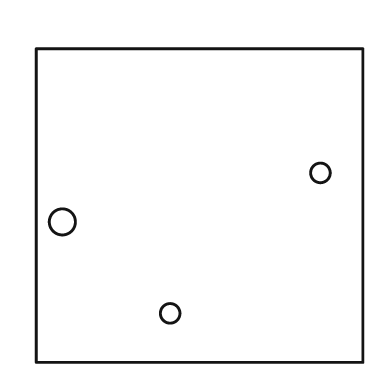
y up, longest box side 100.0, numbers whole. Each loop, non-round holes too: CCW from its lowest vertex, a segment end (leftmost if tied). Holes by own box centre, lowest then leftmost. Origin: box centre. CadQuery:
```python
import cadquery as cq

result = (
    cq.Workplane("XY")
    .moveTo(-50.0, -48.0)
    .lineTo(50.0, -48.0)
    .lineTo(50.0, 48.0)
    .lineTo(-50.0, 48.0)
    .close()
    .moveTo(-9.0, -33.0)
    .circle(3.0)
    .moveTo(-42.0, -5.0)
    .circle(4.0)
    .moveTo(37.0, 10.0)
    .circle(3.0)
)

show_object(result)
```